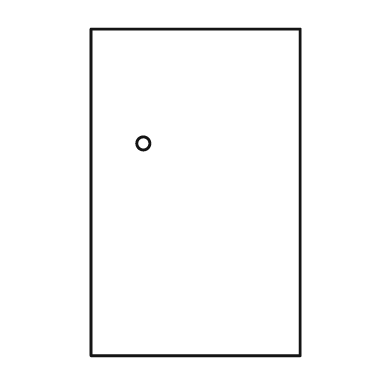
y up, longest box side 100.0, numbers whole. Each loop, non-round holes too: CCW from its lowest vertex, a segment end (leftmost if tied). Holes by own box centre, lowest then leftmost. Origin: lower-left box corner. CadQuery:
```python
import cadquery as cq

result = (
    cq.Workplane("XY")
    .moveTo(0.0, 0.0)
    .lineTo(64.0, 0.0)
    .lineTo(64.0, 100.0)
    .lineTo(0.0, 100.0)
    .close()
    .moveTo(16.0, 65.0)
    .circle(2.0)
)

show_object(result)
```